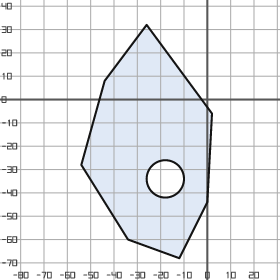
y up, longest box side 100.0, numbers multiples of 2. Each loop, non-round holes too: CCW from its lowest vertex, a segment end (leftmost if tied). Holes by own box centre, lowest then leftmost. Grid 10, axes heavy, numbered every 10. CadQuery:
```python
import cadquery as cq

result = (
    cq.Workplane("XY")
    .moveTo(-12.0, -68.0)
    .lineTo(0.0, -44.0)
    .lineTo(2.0, -6.0)
    .lineTo(-26.0, 32.0)
    .lineTo(-44.0, 8.0)
    .lineTo(-54.0, -28.0)
    .lineTo(-34.0, -60.0)
    .close()
    .moveTo(-18.0, -34.0)
    .circle(8.0)
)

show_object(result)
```